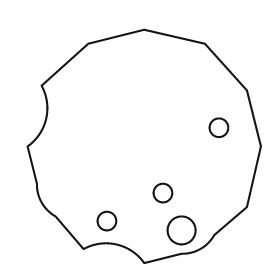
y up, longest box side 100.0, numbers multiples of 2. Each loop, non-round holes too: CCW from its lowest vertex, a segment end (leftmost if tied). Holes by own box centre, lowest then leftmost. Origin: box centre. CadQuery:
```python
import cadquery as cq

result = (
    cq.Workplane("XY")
    .moveTo(0.0, -50.0)
    .lineTo(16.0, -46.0)
    .threePointArc((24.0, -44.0), (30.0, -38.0))
    .lineTo(44.0, -26.0)
    .lineTo(50.0, 0.0)
    .lineTo(44.0, 24.0)
    .lineTo(26.0, 44.0)
    .lineTo(0.0, 50.0)
    .lineTo(-24.0, 44.0)
    .lineTo(-44.0, 26.0)
    .threePointArc((-42.0, 12.0), (-50.0, 0.0))
    .lineTo(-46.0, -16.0)
    .threePointArc((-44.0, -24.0), (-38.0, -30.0))
    .lineTo(-26.0, -44.0)
    .threePointArc((-12.0, -42.0), (0.0, -50.0))
    .close()
    .moveTo(16.0, -36.0)
    .circle(6.0)
    .moveTo(-16.0, -32.0)
    .circle(4.0)
    .moveTo(8.0, -20.0)
    .circle(4.0)
    .moveTo(32.0, 8.0)
    .circle(4.0)
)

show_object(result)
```